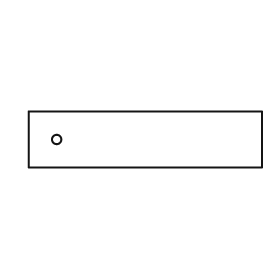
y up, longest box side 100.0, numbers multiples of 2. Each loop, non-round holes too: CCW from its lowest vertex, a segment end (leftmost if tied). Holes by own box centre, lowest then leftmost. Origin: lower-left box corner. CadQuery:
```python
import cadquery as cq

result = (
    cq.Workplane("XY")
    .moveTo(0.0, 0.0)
    .lineTo(100.0, 0.0)
    .lineTo(100.0, 24.0)
    .lineTo(0.0, 24.0)
    .close()
    .moveTo(12.0, 12.0)
    .circle(2.0)
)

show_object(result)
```